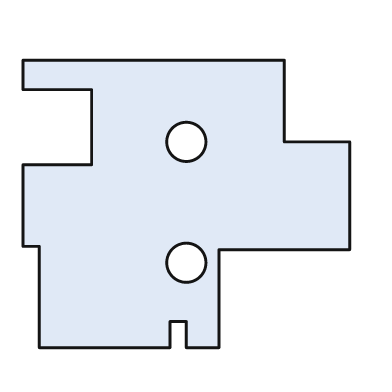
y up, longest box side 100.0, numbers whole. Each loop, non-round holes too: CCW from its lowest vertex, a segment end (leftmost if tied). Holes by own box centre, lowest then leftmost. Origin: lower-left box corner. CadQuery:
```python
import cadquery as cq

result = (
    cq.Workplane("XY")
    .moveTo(5.0, 0.0)
    .lineTo(45.0, 0.0)
    .lineTo(45.0, 8.0)
    .lineTo(50.0, 8.0)
    .lineTo(50.0, 0.0)
    .lineTo(60.0, 0.0)
    .lineTo(60.0, 30.0)
    .lineTo(100.0, 30.0)
    .lineTo(100.0, 63.0)
    .lineTo(80.0, 63.0)
    .lineTo(80.0, 88.0)
    .lineTo(0.0, 88.0)
    .lineTo(0.0, 79.0)
    .lineTo(21.0, 79.0)
    .lineTo(21.0, 56.0)
    .lineTo(0.0, 56.0)
    .lineTo(0.0, 31.0)
    .lineTo(5.0, 31.0)
    .close()
    .moveTo(50.0, 26.0)
    .circle(6.0)
    .moveTo(50.0, 63.0)
    .circle(6.0)
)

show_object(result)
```